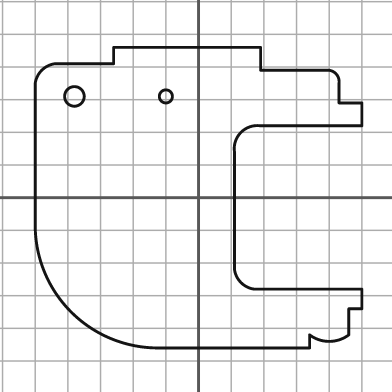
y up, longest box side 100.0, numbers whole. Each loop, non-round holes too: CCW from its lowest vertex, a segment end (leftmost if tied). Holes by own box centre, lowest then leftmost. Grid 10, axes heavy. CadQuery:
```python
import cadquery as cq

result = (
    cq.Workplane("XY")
    .moveTo(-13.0, -46.0)
    .lineTo(34.0, -46.0)
    .lineTo(34.0, -42.0)
    .threePointArc((40.0, -44.0), (46.0, -42.0))
    .lineTo(46.0, -34.0)
    .lineTo(50.0, -34.0)
    .lineTo(50.0, -28.0)
    .lineTo(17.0, -28.0)
    .threePointArc((13.0, -26.0), (11.0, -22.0))
    .lineTo(11.0, 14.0)
    .threePointArc((13.0, 20.0), (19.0, 22.0))
    .lineTo(50.0, 22.0)
    .lineTo(50.0, 29.0)
    .lineTo(43.0, 29.0)
    .lineTo(43.0, 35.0)
    .threePointArc((42.0, 38.0), (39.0, 39.0))
    .lineTo(19.0, 39.0)
    .lineTo(19.0, 46.0)
    .lineTo(-26.0, 46.0)
    .lineTo(-26.0, 41.0)
    .lineTo(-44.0, 41.0)
    .threePointArc((-48.0, 39.0), (-50.0, 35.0))
    .lineTo(-50.0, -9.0)
    .threePointArc((-39.0, -35.0), (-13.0, -46.0))
    .close()
    .moveTo(-38.0, 31.0)
    .circle(3.0)
    .moveTo(-10.0, 31.0)
    .circle(2.0)
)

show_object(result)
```